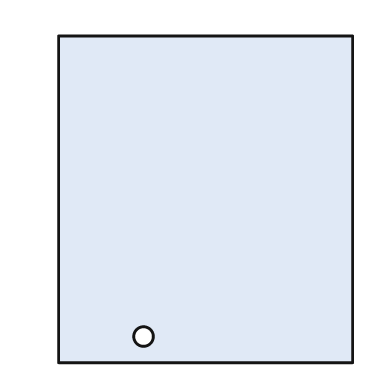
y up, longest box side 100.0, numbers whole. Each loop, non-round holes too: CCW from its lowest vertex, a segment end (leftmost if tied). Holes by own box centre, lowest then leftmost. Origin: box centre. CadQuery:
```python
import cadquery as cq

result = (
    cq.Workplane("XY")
    .moveTo(-45.0, -50.0)
    .lineTo(45.0, -50.0)
    .lineTo(45.0, 50.0)
    .lineTo(-45.0, 50.0)
    .close()
    .moveTo(-19.0, -42.0)
    .circle(3.0)
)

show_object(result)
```